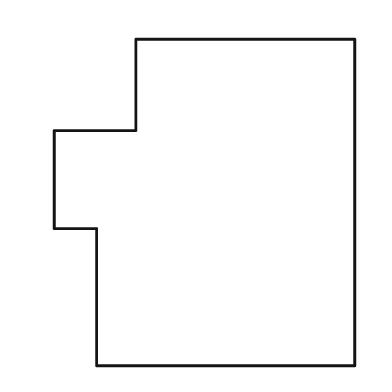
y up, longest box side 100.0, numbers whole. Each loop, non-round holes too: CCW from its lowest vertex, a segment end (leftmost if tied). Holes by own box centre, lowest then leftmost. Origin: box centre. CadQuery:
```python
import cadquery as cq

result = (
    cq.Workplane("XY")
    .moveTo(-33.0, -50.0)
    .lineTo(46.0, -50.0)
    .lineTo(46.0, 50.0)
    .lineTo(-21.0, 50.0)
    .lineTo(-21.0, 22.0)
    .lineTo(-46.0, 22.0)
    .lineTo(-46.0, -8.0)
    .lineTo(-33.0, -8.0)
    .close()
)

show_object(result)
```